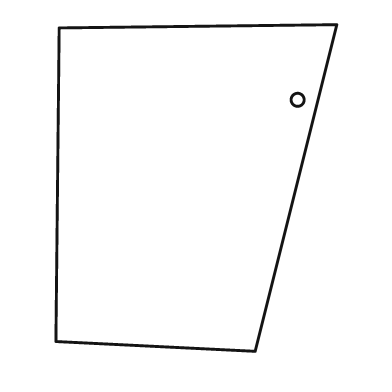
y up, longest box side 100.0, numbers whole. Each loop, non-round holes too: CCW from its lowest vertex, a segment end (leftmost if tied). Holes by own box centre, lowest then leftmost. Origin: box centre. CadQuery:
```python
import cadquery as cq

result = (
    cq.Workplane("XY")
    .moveTo(18.0, -50.0)
    .lineTo(43.0, 50.0)
    .lineTo(-42.0, 49.0)
    .lineTo(-43.0, -47.0)
    .close()
    .moveTo(31.0, 27.0)
    .circle(2.0)
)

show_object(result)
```